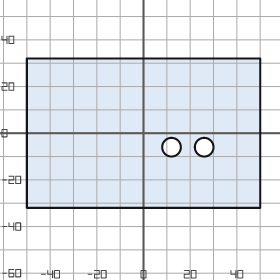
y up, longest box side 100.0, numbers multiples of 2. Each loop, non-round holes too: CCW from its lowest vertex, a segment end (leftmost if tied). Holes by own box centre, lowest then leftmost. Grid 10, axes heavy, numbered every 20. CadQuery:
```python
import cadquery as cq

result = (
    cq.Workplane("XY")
    .moveTo(-50.0, -32.0)
    .lineTo(50.0, -32.0)
    .lineTo(50.0, 32.0)
    .lineTo(-50.0, 32.0)
    .close()
    .moveTo(12.0, -6.0)
    .circle(4.0)
    .moveTo(26.0, -6.0)
    .circle(4.0)
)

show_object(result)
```